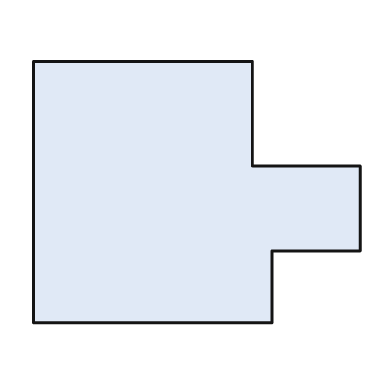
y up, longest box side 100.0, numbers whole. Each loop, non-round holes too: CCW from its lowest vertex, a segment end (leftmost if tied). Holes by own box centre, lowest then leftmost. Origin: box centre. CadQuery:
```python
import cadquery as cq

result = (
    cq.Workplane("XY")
    .moveTo(-50.0, -40.0)
    .lineTo(23.0, -40.0)
    .lineTo(23.0, -18.0)
    .lineTo(50.0, -18.0)
    .lineTo(50.0, 8.0)
    .lineTo(17.0, 8.0)
    .lineTo(17.0, 40.0)
    .lineTo(-50.0, 40.0)
    .close()
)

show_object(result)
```